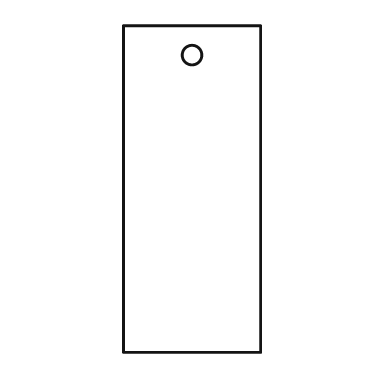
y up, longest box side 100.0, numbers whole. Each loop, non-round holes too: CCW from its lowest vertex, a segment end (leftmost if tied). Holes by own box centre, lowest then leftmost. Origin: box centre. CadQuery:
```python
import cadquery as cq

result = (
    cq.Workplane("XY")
    .moveTo(-21.0, -50.0)
    .lineTo(21.0, -50.0)
    .lineTo(21.0, 50.0)
    .lineTo(-21.0, 50.0)
    .close()
    .moveTo(0.0, 41.0)
    .circle(3.0)
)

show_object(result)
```